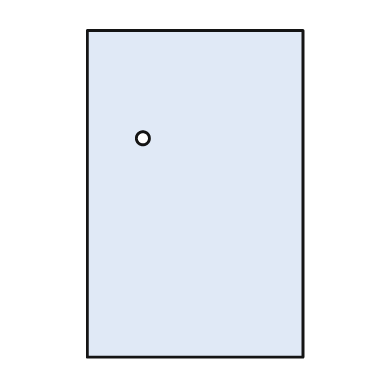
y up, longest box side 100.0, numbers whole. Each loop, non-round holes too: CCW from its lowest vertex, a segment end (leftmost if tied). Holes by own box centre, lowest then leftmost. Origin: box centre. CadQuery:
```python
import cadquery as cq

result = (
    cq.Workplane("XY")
    .moveTo(-33.0, -50.0)
    .lineTo(33.0, -50.0)
    .lineTo(33.0, 50.0)
    .lineTo(-33.0, 50.0)
    .close()
    .moveTo(-16.0, 17.0)
    .circle(2.0)
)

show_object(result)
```